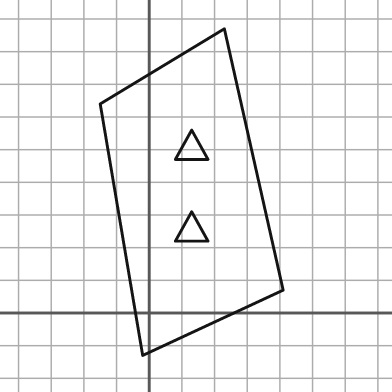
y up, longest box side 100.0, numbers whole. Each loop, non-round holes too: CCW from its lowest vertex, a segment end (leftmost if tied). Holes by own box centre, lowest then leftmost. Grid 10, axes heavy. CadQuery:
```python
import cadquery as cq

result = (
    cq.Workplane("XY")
    .moveTo(-2.0, -13.0)
    .lineTo(41.0, 7.0)
    .lineTo(23.0, 87.0)
    .lineTo(-15.0, 64.0)
    .close()
    .moveTo(8.0, 22.0)
    .lineTo(18.0, 22.0)
    .lineTo(13.0, 31.0)
    .close()
    .moveTo(8.0, 47.0)
    .lineTo(18.0, 47.0)
    .lineTo(13.0, 56.0)
    .close()
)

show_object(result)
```